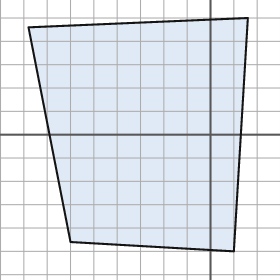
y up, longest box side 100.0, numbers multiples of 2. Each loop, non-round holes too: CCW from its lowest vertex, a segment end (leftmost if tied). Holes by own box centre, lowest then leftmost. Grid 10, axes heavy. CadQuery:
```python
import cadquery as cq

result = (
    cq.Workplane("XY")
    .moveTo(10.0, -50.0)
    .lineTo(16.0, 50.0)
    .lineTo(-78.0, 46.0)
    .lineTo(-60.0, -46.0)
    .close()
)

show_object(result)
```